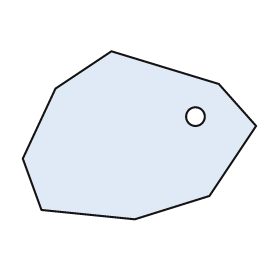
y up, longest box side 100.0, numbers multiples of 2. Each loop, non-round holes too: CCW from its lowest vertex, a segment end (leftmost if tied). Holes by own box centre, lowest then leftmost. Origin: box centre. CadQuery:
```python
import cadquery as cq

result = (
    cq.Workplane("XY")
    .moveTo(-2.0, -36.0)
    .lineTo(30.0, -26.0)
    .lineTo(50.0, 4.0)
    .lineTo(34.0, 22.0)
    .lineTo(-12.0, 36.0)
    .lineTo(-36.0, 20.0)
    .lineTo(-50.0, -10.0)
    .lineTo(-42.0, -32.0)
    .close()
    .moveTo(24.0, 8.0)
    .circle(4.0)
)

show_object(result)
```